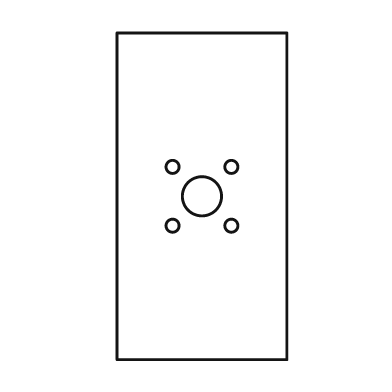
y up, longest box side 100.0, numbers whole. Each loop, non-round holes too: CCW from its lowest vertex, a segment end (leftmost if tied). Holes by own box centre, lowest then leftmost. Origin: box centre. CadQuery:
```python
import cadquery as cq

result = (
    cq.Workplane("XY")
    .moveTo(-26.0, -50.0)
    .lineTo(26.0, -50.0)
    .lineTo(26.0, 50.0)
    .lineTo(-26.0, 50.0)
    .close()
    .moveTo(-9.0, -9.0)
    .circle(2.0)
    .moveTo(9.0, -9.0)
    .circle(2.0)
    .moveTo(0.0, 0.0)
    .circle(6.0)
    .moveTo(-9.0, 9.0)
    .circle(2.0)
    .moveTo(9.0, 9.0)
    .circle(2.0)
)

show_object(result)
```